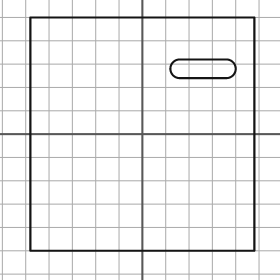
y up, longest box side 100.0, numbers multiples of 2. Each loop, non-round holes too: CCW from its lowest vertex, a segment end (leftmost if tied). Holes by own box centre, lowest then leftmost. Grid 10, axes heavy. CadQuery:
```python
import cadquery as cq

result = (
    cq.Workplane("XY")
    .moveTo(-48.0, -50.0)
    .lineTo(48.0, -50.0)
    .lineTo(48.0, 50.0)
    .lineTo(-48.0, 50.0)
    .close()
    .moveTo(16.0, 24.0)
    .lineTo(36.0, 24.0)
    .threePointArc((40.0, 28.0), (36.0, 32.0))
    .lineTo(16.0, 32.0)
    .threePointArc((12.0, 28.0), (16.0, 24.0))
    .close()
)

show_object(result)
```